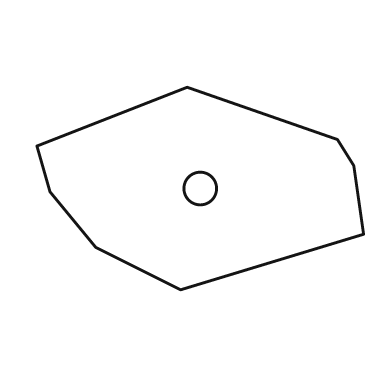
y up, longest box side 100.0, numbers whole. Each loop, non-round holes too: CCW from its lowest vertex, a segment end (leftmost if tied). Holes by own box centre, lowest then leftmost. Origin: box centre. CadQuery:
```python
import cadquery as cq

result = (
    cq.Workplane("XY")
    .moveTo(-6.0, -31.0)
    .lineTo(50.0, -14.0)
    .lineTo(47.0, 7.0)
    .lineTo(42.0, 15.0)
    .lineTo(-4.0, 31.0)
    .lineTo(-50.0, 13.0)
    .lineTo(-46.0, -1.0)
    .lineTo(-32.0, -18.0)
    .close()
    .moveTo(0.0, 0.0)
    .circle(5.0)
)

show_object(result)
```